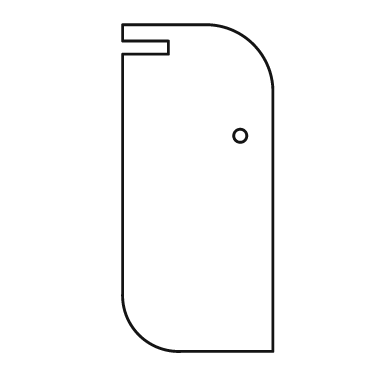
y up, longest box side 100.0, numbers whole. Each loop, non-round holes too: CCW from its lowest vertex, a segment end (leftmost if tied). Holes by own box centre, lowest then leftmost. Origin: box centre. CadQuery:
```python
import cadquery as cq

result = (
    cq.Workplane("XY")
    .moveTo(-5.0, -50.0)
    .lineTo(23.0, -50.0)
    .lineTo(23.0, 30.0)
    .threePointArc((17.0, 44.0), (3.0, 50.0))
    .lineTo(-23.0, 50.0)
    .lineTo(-23.0, 45.0)
    .lineTo(-9.0, 45.0)
    .lineTo(-9.0, 41.0)
    .lineTo(-23.0, 41.0)
    .lineTo(-23.0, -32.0)
    .threePointArc((-18.0, -45.0), (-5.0, -50.0))
    .close()
    .moveTo(13.0, 16.0)
    .circle(2.0)
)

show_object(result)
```